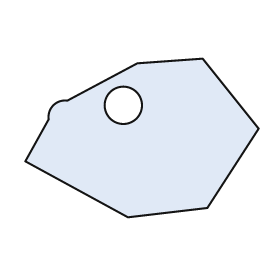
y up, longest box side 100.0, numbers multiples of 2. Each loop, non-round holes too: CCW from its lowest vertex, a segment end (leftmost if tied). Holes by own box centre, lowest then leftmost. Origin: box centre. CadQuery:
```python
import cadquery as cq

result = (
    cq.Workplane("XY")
    .moveTo(-6.0, -34.0)
    .lineTo(28.0, -30.0)
    .lineTo(50.0, 4.0)
    .lineTo(26.0, 34.0)
    .lineTo(-2.0, 32.0)
    .lineTo(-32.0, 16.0)
    .threePointArc((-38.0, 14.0), (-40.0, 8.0))
    .lineTo(-50.0, -10.0)
    .close()
    .moveTo(-8.0, 14.0)
    .circle(8.0)
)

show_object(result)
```